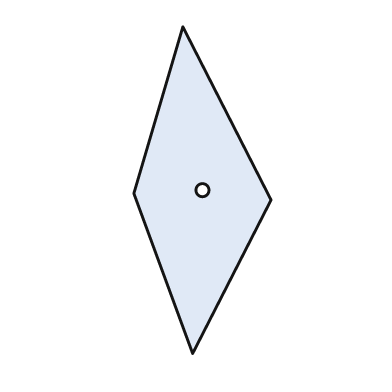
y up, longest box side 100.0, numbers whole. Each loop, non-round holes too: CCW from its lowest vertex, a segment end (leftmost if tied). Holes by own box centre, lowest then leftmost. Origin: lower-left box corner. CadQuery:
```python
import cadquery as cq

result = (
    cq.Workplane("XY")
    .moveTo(18.0, 0.0)
    .lineTo(42.0, 47.0)
    .lineTo(15.0, 100.0)
    .lineTo(0.0, 49.0)
    .close()
    .moveTo(21.0, 50.0)
    .circle(2.0)
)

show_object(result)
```